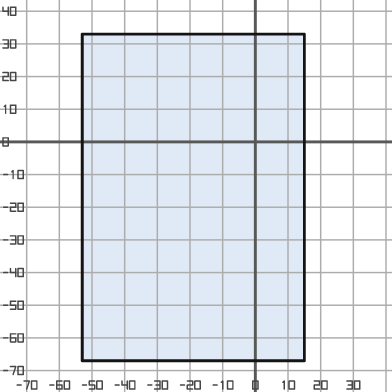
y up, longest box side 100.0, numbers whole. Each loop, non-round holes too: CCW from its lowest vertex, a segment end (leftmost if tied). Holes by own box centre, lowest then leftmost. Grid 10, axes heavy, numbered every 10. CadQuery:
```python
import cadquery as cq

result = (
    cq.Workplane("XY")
    .moveTo(-53.0, -67.0)
    .lineTo(15.0, -67.0)
    .lineTo(15.0, 33.0)
    .lineTo(-53.0, 33.0)
    .close()
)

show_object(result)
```